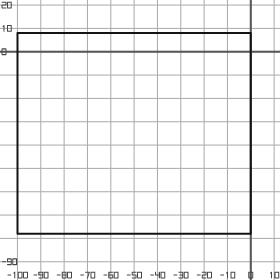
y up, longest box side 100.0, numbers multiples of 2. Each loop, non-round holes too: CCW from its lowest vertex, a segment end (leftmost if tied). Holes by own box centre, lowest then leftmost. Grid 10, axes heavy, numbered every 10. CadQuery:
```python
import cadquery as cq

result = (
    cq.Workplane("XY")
    .moveTo(-100.0, -78.0)
    .lineTo(0.0, -78.0)
    .lineTo(0.0, 8.0)
    .lineTo(-100.0, 8.0)
    .close()
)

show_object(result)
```